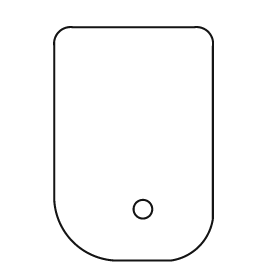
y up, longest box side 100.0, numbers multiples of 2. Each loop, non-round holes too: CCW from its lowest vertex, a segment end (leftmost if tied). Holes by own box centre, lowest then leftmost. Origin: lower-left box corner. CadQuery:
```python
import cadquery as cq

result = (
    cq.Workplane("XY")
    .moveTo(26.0, 0.0)
    .lineTo(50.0, 0.0)
    .threePointArc((62.0, 6.0), (68.0, 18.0))
    .lineTo(68.0, 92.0)
    .threePointArc((66.0, 98.0), (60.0, 100.0))
    .lineTo(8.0, 100.0)
    .threePointArc((2.0, 98.0), (0.0, 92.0))
    .lineTo(0.0, 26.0)
    .threePointArc((8.0, 8.0), (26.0, 0.0))
    .close()
    .moveTo(38.0, 22.0)
    .circle(4.0)
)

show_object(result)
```